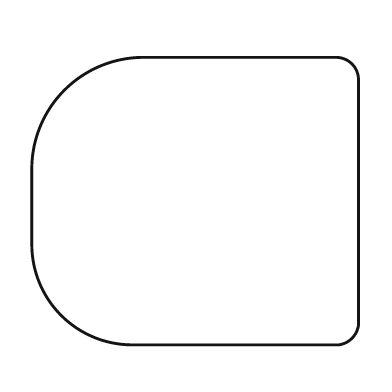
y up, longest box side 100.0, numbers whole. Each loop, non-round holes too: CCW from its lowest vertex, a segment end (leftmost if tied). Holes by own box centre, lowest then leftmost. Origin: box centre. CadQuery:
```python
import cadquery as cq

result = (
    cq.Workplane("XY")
    .moveTo(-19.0, -44.0)
    .lineTo(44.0, -44.0)
    .threePointArc((48.0, -42.0), (50.0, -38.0))
    .lineTo(50.0, 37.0)
    .threePointArc((48.0, 42.0), (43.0, 44.0))
    .lineTo(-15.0, 44.0)
    .threePointArc((-40.0, 34.0), (-50.0, 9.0))
    .lineTo(-50.0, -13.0)
    .threePointArc((-41.0, -35.0), (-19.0, -44.0))
    .close()
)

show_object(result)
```